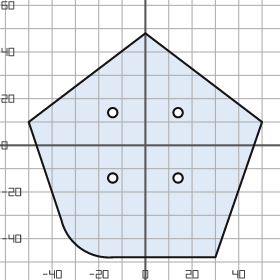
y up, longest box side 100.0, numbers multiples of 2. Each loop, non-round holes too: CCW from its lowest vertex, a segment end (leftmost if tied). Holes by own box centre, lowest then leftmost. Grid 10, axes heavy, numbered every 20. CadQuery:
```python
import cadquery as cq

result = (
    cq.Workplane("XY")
    .moveTo(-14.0, -48.0)
    .lineTo(30.0, -48.0)
    .lineTo(50.0, 10.0)
    .lineTo(0.0, 48.0)
    .lineTo(-50.0, 10.0)
    .lineTo(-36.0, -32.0)
    .threePointArc((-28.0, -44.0), (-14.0, -48.0))
    .close()
    .moveTo(-14.0, -14.0)
    .circle(2.0)
    .moveTo(14.0, -14.0)
    .circle(2.0)
    .moveTo(-14.0, 14.0)
    .circle(2.0)
    .moveTo(14.0, 14.0)
    .circle(2.0)
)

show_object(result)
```